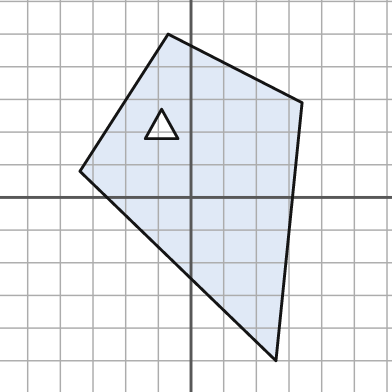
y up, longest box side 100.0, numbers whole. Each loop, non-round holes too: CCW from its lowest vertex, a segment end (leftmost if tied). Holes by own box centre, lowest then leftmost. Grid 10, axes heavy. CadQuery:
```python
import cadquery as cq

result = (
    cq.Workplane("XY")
    .moveTo(26.0, -50.0)
    .lineTo(34.0, 29.0)
    .lineTo(-7.0, 50.0)
    .lineTo(-34.0, 8.0)
    .close()
    .moveTo(-14.0, 18.0)
    .lineTo(-4.0, 18.0)
    .lineTo(-9.0, 27.0)
    .close()
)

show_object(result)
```